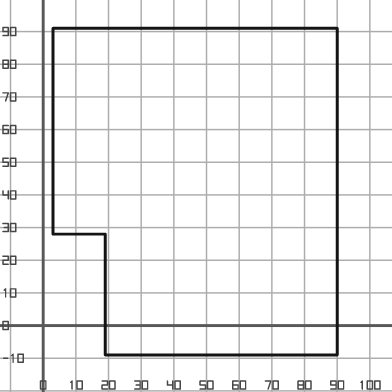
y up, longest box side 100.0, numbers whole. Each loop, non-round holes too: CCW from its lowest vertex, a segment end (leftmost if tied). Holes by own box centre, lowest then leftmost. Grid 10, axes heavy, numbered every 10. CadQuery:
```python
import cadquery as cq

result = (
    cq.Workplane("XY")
    .moveTo(19.0, -9.0)
    .lineTo(90.0, -9.0)
    .lineTo(90.0, 91.0)
    .lineTo(3.0, 91.0)
    .lineTo(3.0, 28.0)
    .lineTo(19.0, 28.0)
    .close()
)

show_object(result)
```